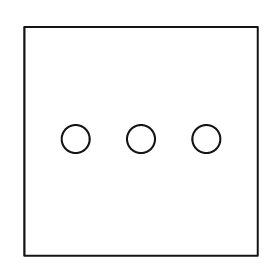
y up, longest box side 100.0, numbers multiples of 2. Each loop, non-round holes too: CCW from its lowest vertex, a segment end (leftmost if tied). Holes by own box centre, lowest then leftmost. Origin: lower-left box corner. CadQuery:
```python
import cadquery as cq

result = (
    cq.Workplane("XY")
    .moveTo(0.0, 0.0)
    .lineTo(100.0, 0.0)
    .lineTo(100.0, 98.0)
    .lineTo(0.0, 98.0)
    .close()
    .moveTo(22.0, 50.0)
    .circle(6.0)
    .moveTo(50.0, 50.0)
    .circle(6.0)
    .moveTo(78.0, 50.0)
    .circle(6.0)
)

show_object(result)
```